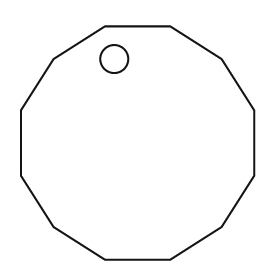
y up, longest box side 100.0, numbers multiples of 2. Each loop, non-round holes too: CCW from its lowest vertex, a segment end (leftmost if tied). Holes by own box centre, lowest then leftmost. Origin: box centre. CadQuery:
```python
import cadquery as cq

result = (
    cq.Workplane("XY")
    .moveTo(-14.0, -50.0)
    .lineTo(14.0, -50.0)
    .lineTo(36.0, -36.0)
    .lineTo(50.0, -14.0)
    .lineTo(50.0, 14.0)
    .lineTo(36.0, 36.0)
    .lineTo(14.0, 50.0)
    .lineTo(-14.0, 50.0)
    .lineTo(-36.0, 36.0)
    .lineTo(-50.0, 14.0)
    .lineTo(-50.0, -14.0)
    .lineTo(-36.0, -36.0)
    .close()
    .moveTo(-10.0, 36.0)
    .circle(6.0)
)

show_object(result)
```